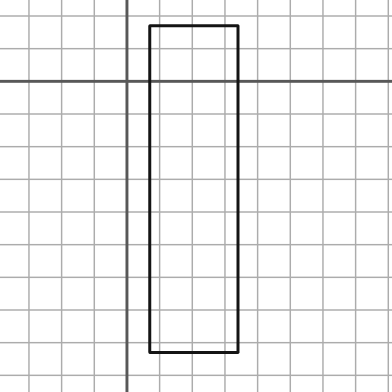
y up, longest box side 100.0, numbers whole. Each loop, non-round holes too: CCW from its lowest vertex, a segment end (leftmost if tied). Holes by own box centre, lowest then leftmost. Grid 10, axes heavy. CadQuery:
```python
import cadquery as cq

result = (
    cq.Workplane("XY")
    .moveTo(7.0, -83.0)
    .lineTo(34.0, -83.0)
    .lineTo(34.0, 17.0)
    .lineTo(7.0, 17.0)
    .close()
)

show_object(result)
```